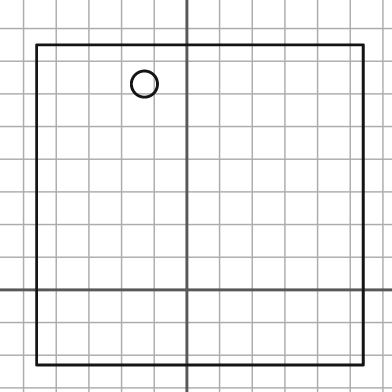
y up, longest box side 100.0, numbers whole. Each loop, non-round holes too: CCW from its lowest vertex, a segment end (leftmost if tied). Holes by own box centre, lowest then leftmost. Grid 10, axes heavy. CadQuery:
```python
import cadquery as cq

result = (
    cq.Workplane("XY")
    .moveTo(-46.0, -23.0)
    .lineTo(54.0, -23.0)
    .lineTo(54.0, 75.0)
    .lineTo(-46.0, 75.0)
    .close()
    .moveTo(-13.0, 63.0)
    .circle(4.0)
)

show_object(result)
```